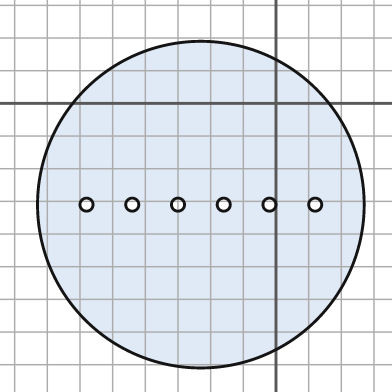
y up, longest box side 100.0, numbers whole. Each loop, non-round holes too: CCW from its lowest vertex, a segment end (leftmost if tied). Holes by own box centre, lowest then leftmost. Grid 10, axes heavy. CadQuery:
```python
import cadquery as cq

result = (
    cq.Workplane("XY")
    .moveTo(-23.0, -31.0)
    .circle(50.0)
    .moveTo(-58.0, -31.0)
    .circle(2.0)
    .moveTo(-44.0, -31.0)
    .circle(2.0)
    .moveTo(-30.0, -31.0)
    .circle(2.0)
    .moveTo(-16.0, -31.0)
    .circle(2.0)
    .moveTo(-2.0, -31.0)
    .circle(2.0)
    .moveTo(12.0, -31.0)
    .circle(2.0)
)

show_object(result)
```